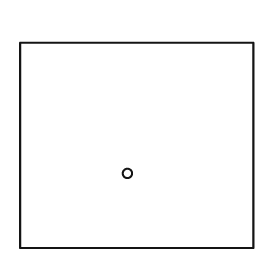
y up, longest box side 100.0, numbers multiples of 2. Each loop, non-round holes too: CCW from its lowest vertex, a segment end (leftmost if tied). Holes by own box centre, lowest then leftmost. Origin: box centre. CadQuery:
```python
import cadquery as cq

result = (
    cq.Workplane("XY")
    .moveTo(-50.0, -44.0)
    .lineTo(50.0, -44.0)
    .lineTo(50.0, 44.0)
    .lineTo(-50.0, 44.0)
    .close()
    .moveTo(-4.0, -12.0)
    .circle(2.0)
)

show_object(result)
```